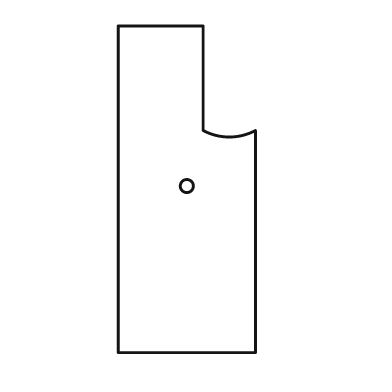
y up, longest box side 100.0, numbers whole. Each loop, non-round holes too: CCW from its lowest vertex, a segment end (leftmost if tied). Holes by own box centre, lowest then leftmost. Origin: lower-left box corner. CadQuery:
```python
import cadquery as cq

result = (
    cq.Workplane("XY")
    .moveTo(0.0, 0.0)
    .lineTo(42.0, 0.0)
    .lineTo(42.0, 68.0)
    .threePointArc((34.0, 66.0), (26.0, 68.0))
    .lineTo(26.0, 100.0)
    .lineTo(0.0, 100.0)
    .close()
    .moveTo(21.0, 51.0)
    .circle(2.0)
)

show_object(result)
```